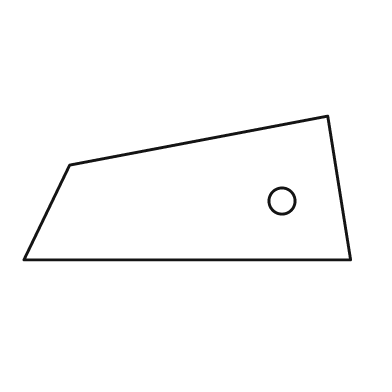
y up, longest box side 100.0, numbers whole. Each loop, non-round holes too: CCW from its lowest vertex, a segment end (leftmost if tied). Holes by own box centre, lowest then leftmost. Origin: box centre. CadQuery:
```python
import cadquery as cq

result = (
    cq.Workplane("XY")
    .moveTo(-50.0, -22.0)
    .lineTo(50.0, -22.0)
    .lineTo(43.0, 22.0)
    .lineTo(-36.0, 7.0)
    .close()
    .moveTo(29.0, -4.0)
    .circle(4.0)
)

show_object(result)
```